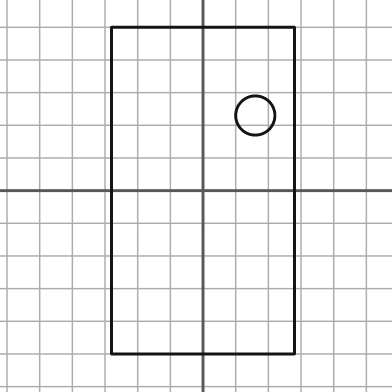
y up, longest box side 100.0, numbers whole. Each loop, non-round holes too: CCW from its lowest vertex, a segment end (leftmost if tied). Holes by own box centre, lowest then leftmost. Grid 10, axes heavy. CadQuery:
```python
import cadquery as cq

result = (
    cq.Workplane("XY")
    .moveTo(-28.0, -50.0)
    .lineTo(28.0, -50.0)
    .lineTo(28.0, 50.0)
    .lineTo(-28.0, 50.0)
    .close()
    .moveTo(16.0, 23.0)
    .circle(6.0)
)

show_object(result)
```